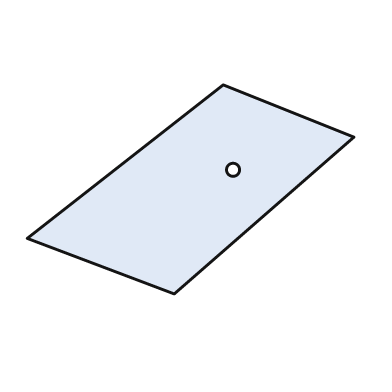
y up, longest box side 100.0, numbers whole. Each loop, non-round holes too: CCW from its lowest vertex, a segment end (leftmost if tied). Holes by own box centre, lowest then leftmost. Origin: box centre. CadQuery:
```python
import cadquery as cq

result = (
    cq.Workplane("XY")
    .moveTo(-5.0, -32.0)
    .lineTo(50.0, 16.0)
    .lineTo(10.0, 32.0)
    .lineTo(-50.0, -15.0)
    .close()
    .moveTo(13.0, 6.0)
    .circle(2.0)
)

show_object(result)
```